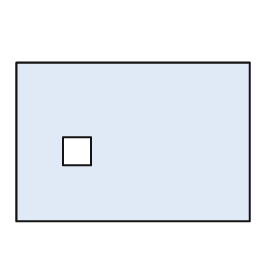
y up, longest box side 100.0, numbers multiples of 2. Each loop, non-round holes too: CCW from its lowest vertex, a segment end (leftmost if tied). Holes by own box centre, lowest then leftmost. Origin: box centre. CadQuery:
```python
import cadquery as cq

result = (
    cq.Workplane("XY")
    .moveTo(-50.0, -34.0)
    .lineTo(50.0, -34.0)
    .lineTo(50.0, 34.0)
    .lineTo(-50.0, 34.0)
    .close()
    .moveTo(-30.0, -10.0)
    .lineTo(-18.0, -10.0)
    .lineTo(-18.0, 2.0)
    .lineTo(-30.0, 2.0)
    .close()
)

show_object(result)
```